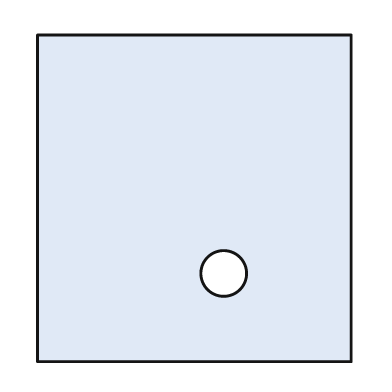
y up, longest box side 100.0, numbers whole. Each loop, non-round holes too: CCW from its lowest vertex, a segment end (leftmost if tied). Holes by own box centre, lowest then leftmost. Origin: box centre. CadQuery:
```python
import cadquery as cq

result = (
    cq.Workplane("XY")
    .moveTo(-48.0, -50.0)
    .lineTo(48.0, -50.0)
    .lineTo(48.0, 50.0)
    .lineTo(-48.0, 50.0)
    .close()
    .moveTo(9.0, -23.0)
    .circle(7.0)
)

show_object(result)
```